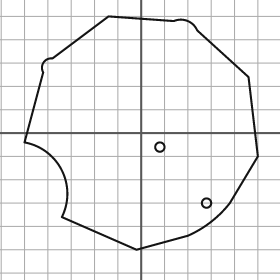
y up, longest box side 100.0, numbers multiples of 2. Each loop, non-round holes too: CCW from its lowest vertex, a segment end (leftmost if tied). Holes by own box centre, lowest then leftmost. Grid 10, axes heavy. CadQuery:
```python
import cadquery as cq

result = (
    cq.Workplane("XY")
    .moveTo(-2.0, -50.0)
    .lineTo(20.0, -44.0)
    .threePointArc((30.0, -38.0), (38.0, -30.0))
    .lineTo(50.0, -10.0)
    .lineTo(46.0, 24.0)
    .lineTo(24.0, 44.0)
    .threePointArc((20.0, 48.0), (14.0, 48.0))
    .lineTo(-14.0, 50.0)
    .lineTo(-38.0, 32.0)
    .threePointArc((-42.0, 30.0), (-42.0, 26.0))
    .lineTo(-50.0, -4.0)
    .threePointArc((-34.0, -16.0), (-34.0, -36.0))
    .close()
    .moveTo(28.0, -30.0)
    .circle(2.0)
    .moveTo(8.0, -6.0)
    .circle(2.0)
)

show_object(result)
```